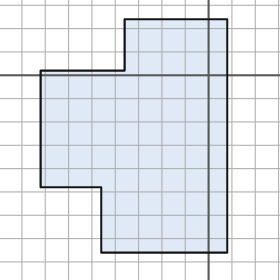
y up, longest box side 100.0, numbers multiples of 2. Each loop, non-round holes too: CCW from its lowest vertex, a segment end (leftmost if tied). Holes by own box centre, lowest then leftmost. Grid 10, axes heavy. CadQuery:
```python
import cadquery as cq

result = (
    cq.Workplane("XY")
    .moveTo(-46.0, -76.0)
    .lineTo(8.0, -76.0)
    .lineTo(8.0, 24.0)
    .lineTo(-36.0, 24.0)
    .lineTo(-36.0, 2.0)
    .lineTo(-72.0, 2.0)
    .lineTo(-72.0, -48.0)
    .lineTo(-46.0, -48.0)
    .close()
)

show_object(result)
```